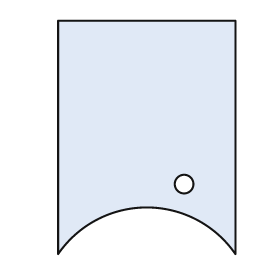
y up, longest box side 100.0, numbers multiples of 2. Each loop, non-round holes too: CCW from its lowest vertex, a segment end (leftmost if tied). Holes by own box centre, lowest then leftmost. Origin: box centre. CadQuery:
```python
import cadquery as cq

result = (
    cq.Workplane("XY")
    .moveTo(-38.0, -50.0)
    .threePointArc((0.0, -30.0), (38.0, -50.0))
    .lineTo(38.0, 50.0)
    .lineTo(-38.0, 50.0)
    .close()
    .moveTo(16.0, -20.0)
    .circle(4.0)
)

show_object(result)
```